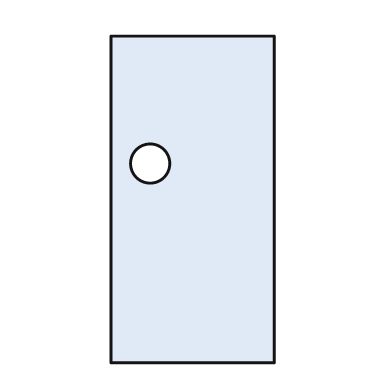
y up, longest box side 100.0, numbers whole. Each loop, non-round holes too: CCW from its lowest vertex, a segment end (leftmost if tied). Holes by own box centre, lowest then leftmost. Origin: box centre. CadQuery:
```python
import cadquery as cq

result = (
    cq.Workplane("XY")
    .moveTo(-25.0, -50.0)
    .lineTo(25.0, -50.0)
    .lineTo(25.0, 50.0)
    .lineTo(-25.0, 50.0)
    .close()
    .moveTo(-13.0, 11.0)
    .circle(6.0)
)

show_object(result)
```